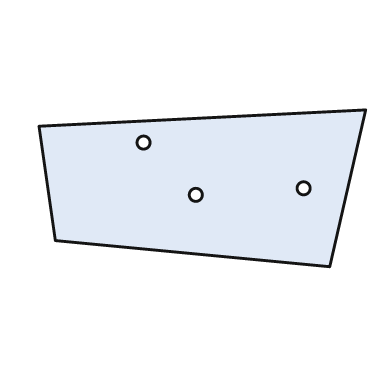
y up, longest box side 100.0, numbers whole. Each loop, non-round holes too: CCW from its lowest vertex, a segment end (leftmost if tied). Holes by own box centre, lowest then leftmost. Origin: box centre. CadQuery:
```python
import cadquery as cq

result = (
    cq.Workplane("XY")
    .moveTo(39.0, -24.0)
    .lineTo(50.0, 24.0)
    .lineTo(-50.0, 19.0)
    .lineTo(-45.0, -16.0)
    .close()
    .moveTo(-2.0, -2.0)
    .circle(2.0)
    .moveTo(31.0, 0.0)
    .circle(2.0)
    .moveTo(-18.0, 14.0)
    .circle(2.0)
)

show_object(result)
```